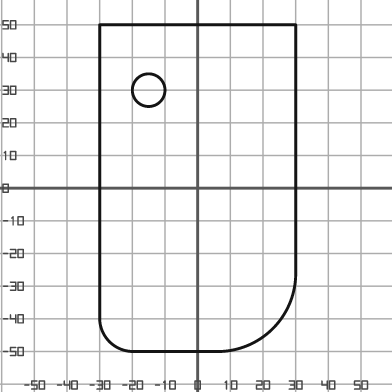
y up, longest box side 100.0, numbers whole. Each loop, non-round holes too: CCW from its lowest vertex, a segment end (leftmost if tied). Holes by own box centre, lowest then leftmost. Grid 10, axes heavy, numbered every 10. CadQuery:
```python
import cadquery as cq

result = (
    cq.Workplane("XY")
    .moveTo(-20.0, -50.0)
    .lineTo(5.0, -50.0)
    .threePointArc((23.0, -43.0), (30.0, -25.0))
    .lineTo(30.0, 50.0)
    .lineTo(-30.0, 50.0)
    .lineTo(-30.0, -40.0)
    .threePointArc((-27.0, -47.0), (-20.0, -50.0))
    .close()
    .moveTo(-15.0, 30.0)
    .circle(5.0)
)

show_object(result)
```